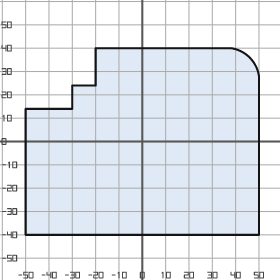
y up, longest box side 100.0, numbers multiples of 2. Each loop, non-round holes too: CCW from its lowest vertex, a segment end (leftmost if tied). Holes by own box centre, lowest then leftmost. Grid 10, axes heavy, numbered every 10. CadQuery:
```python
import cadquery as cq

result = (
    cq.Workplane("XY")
    .moveTo(-50.0, -40.0)
    .lineTo(50.0, -40.0)
    .lineTo(50.0, 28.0)
    .threePointArc((46.0, 36.0), (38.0, 40.0))
    .lineTo(-20.0, 40.0)
    .lineTo(-20.0, 24.0)
    .lineTo(-30.0, 24.0)
    .lineTo(-30.0, 14.0)
    .lineTo(-50.0, 14.0)
    .close()
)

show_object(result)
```